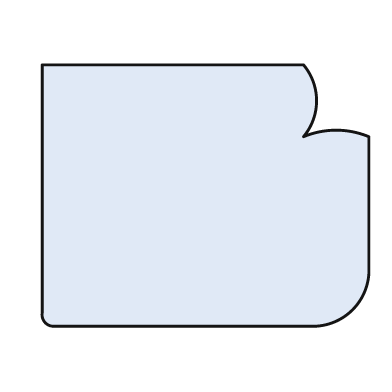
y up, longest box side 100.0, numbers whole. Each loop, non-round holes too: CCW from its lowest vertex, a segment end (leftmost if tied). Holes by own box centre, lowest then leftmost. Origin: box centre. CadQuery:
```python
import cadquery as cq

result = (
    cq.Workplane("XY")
    .moveTo(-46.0, -40.0)
    .lineTo(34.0, -40.0)
    .threePointArc((45.0, -35.0), (50.0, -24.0))
    .lineTo(50.0, 18.0)
    .threePointArc((40.0, 20.0), (30.0, 18.0))
    .threePointArc((34.0, 29.0), (30.0, 40.0))
    .lineTo(-50.0, 40.0)
    .lineTo(-50.0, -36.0)
    .threePointArc((-49.0, -39.0), (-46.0, -40.0))
    .close()
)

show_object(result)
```